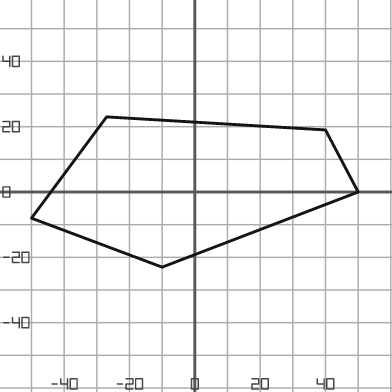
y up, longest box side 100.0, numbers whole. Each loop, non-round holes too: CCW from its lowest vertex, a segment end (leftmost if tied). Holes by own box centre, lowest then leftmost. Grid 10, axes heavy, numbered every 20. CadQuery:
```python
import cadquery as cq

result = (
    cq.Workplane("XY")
    .moveTo(-10.0, -23.0)
    .lineTo(50.0, 0.0)
    .lineTo(40.0, 19.0)
    .lineTo(-27.0, 23.0)
    .lineTo(-50.0, -8.0)
    .close()
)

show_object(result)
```